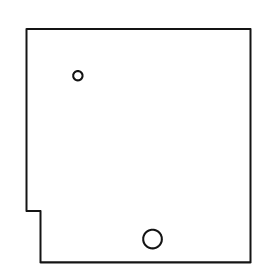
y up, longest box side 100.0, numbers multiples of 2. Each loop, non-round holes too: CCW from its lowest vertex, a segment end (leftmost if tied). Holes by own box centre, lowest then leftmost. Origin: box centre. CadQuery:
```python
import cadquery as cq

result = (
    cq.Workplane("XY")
    .moveTo(-42.0, -50.0)
    .lineTo(48.0, -50.0)
    .lineTo(48.0, 50.0)
    .lineTo(-48.0, 50.0)
    .lineTo(-48.0, -28.0)
    .lineTo(-42.0, -28.0)
    .close()
    .moveTo(6.0, -40.0)
    .circle(4.0)
    .moveTo(-26.0, 30.0)
    .circle(2.0)
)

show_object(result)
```